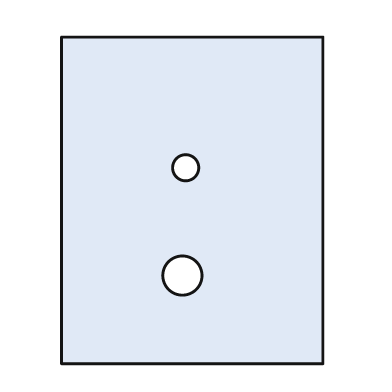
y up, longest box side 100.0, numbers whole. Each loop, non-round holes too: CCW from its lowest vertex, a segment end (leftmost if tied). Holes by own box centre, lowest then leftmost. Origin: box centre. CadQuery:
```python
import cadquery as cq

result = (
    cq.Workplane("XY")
    .moveTo(-40.0, -50.0)
    .lineTo(40.0, -50.0)
    .lineTo(40.0, 50.0)
    .lineTo(-40.0, 50.0)
    .close()
    .moveTo(-3.0, -23.0)
    .circle(6.0)
    .moveTo(-2.0, 10.0)
    .circle(4.0)
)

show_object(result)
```